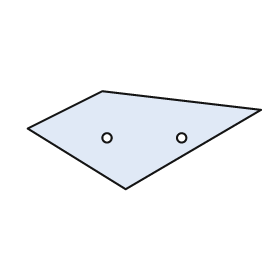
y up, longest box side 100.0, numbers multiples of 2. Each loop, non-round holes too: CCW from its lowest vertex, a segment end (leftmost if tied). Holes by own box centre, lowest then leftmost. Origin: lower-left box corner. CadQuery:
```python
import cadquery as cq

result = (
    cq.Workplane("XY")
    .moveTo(42.0, 0.0)
    .lineTo(100.0, 34.0)
    .lineTo(32.0, 42.0)
    .lineTo(0.0, 26.0)
    .close()
    .moveTo(34.0, 22.0)
    .circle(2.0)
    .moveTo(66.0, 22.0)
    .circle(2.0)
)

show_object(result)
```